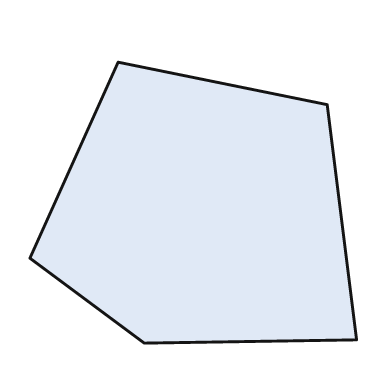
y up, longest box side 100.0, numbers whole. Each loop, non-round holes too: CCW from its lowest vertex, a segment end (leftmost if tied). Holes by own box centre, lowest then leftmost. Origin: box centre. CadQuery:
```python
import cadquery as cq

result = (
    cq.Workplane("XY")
    .moveTo(-15.0, -43.0)
    .lineTo(50.0, -42.0)
    .lineTo(41.0, 30.0)
    .lineTo(-23.0, 43.0)
    .lineTo(-50.0, -17.0)
    .close()
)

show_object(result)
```